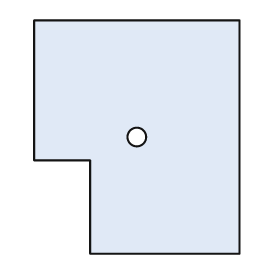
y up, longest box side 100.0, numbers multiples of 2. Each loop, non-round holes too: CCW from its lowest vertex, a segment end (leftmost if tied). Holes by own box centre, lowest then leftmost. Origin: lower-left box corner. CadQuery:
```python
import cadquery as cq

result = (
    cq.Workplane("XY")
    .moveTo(24.0, 0.0)
    .lineTo(88.0, 0.0)
    .lineTo(88.0, 100.0)
    .lineTo(0.0, 100.0)
    .lineTo(0.0, 40.0)
    .lineTo(24.0, 40.0)
    .close()
    .moveTo(44.0, 50.0)
    .circle(4.0)
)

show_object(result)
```